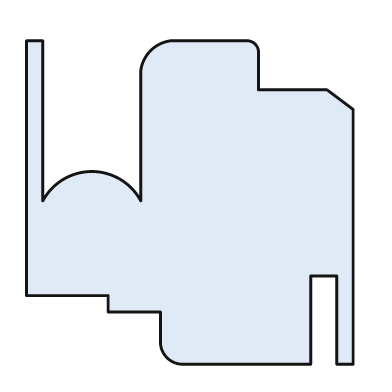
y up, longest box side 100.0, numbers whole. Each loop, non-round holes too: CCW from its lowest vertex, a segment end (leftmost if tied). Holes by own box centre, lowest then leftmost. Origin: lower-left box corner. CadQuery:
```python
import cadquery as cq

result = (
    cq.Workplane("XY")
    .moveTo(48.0, 0.0)
    .lineTo(87.0, 0.0)
    .lineTo(87.0, 27.0)
    .lineTo(95.0, 27.0)
    .lineTo(95.0, 0.0)
    .lineTo(100.0, 0.0)
    .lineTo(100.0, 78.0)
    .lineTo(92.0, 84.0)
    .lineTo(71.0, 84.0)
    .lineTo(71.0, 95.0)
    .threePointArc((70.0, 98.0), (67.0, 99.0))
    .lineTo(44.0, 99.0)
    .threePointArc((38.0, 96.0), (35.0, 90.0))
    .lineTo(35.0, 50.0)
    .threePointArc((20.0, 59.0), (5.0, 50.0))
    .lineTo(5.0, 99.0)
    .lineTo(0.0, 99.0)
    .lineTo(0.0, 21.0)
    .lineTo(25.0, 21.0)
    .lineTo(25.0, 16.0)
    .lineTo(41.0, 16.0)
    .lineTo(41.0, 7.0)
    .threePointArc((43.0, 2.0), (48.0, 0.0))
    .close()
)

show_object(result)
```